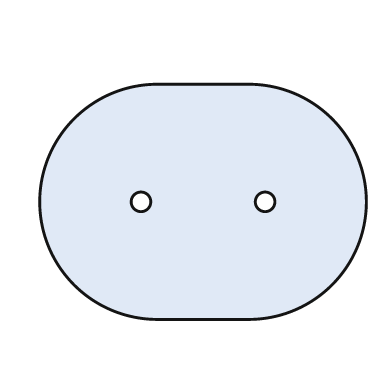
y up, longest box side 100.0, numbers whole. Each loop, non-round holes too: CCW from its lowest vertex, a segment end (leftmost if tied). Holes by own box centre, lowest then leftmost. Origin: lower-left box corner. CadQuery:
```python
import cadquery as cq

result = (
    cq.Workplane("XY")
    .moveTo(36.0, 0.0)
    .lineTo(64.0, 0.0)
    .threePointArc((100.0, 36.0), (64.0, 72.0))
    .lineTo(36.0, 72.0)
    .threePointArc((0.0, 36.0), (36.0, 0.0))
    .close()
    .moveTo(31.0, 36.0)
    .circle(3.0)
    .moveTo(69.0, 36.0)
    .circle(3.0)
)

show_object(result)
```